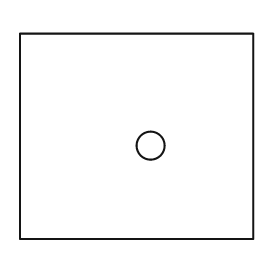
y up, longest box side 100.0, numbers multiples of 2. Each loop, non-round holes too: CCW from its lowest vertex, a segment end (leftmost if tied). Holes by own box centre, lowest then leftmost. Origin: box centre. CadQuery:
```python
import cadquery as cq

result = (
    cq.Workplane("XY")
    .moveTo(-50.0, -44.0)
    .lineTo(50.0, -44.0)
    .lineTo(50.0, 44.0)
    .lineTo(-50.0, 44.0)
    .close()
    .moveTo(6.0, -4.0)
    .circle(6.0)
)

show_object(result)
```